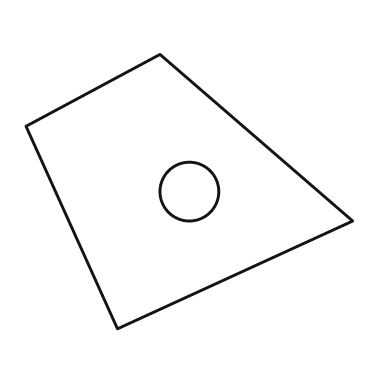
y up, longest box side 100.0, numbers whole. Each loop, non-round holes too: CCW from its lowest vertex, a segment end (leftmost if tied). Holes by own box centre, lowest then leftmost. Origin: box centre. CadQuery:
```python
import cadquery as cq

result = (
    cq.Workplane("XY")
    .moveTo(-22.0, -42.0)
    .lineTo(50.0, -9.0)
    .lineTo(-9.0, 42.0)
    .lineTo(-50.0, 20.0)
    .close()
    .moveTo(0.0, 0.0)
    .circle(9.0)
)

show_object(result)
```